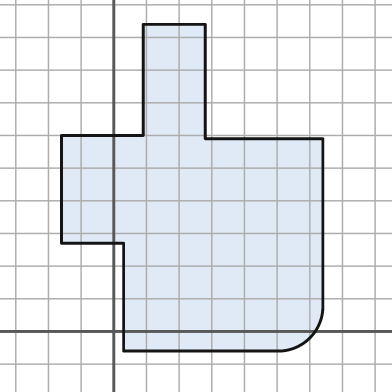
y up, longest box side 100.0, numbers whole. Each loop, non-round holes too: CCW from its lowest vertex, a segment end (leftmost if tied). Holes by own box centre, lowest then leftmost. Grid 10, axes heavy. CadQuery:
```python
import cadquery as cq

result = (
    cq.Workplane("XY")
    .moveTo(3.0, -6.0)
    .lineTo(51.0, -6.0)
    .threePointArc((60.0, -2.0), (64.0, 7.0))
    .lineTo(64.0, 59.0)
    .lineTo(28.0, 59.0)
    .lineTo(28.0, 94.0)
    .lineTo(9.0, 94.0)
    .lineTo(9.0, 60.0)
    .lineTo(-16.0, 60.0)
    .lineTo(-16.0, 27.0)
    .lineTo(3.0, 27.0)
    .close()
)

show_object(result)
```